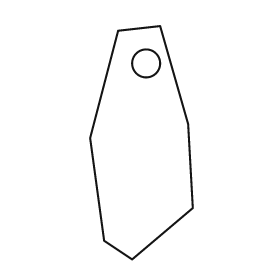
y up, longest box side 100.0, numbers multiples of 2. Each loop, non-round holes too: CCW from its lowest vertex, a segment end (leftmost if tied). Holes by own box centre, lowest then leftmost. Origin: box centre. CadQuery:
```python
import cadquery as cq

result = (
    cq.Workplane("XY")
    .moveTo(-4.0, -50.0)
    .lineTo(22.0, -28.0)
    .lineTo(20.0, 8.0)
    .lineTo(8.0, 50.0)
    .lineTo(-10.0, 48.0)
    .lineTo(-22.0, 2.0)
    .lineTo(-16.0, -42.0)
    .close()
    .moveTo(2.0, 34.0)
    .circle(6.0)
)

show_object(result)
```